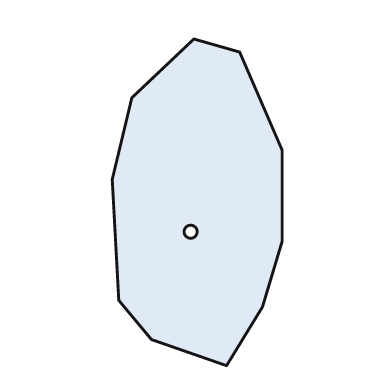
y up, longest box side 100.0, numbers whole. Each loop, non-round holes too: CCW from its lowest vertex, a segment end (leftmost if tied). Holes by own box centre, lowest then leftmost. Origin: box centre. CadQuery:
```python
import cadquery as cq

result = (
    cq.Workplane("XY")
    .moveTo(9.0, -50.0)
    .lineTo(20.0, -32.0)
    .lineTo(26.0, -12.0)
    .lineTo(26.0, 16.0)
    .lineTo(13.0, 46.0)
    .lineTo(-1.0, 50.0)
    .lineTo(-20.0, 32.0)
    .lineTo(-26.0, 7.0)
    .lineTo(-24.0, -30.0)
    .lineTo(-14.0, -42.0)
    .close()
    .moveTo(-2.0, -9.0)
    .circle(2.0)
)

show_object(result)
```